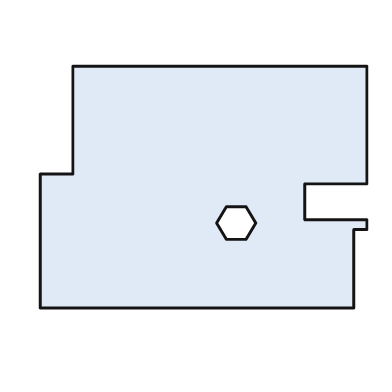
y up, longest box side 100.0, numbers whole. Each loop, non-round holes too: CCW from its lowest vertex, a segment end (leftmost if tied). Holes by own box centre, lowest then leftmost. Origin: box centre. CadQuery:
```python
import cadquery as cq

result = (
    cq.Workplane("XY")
    .moveTo(-50.0, -37.0)
    .lineTo(46.0, -37.0)
    .lineTo(46.0, -13.0)
    .lineTo(50.0, -13.0)
    .lineTo(50.0, -10.0)
    .lineTo(31.0, -10.0)
    .lineTo(31.0, 1.0)
    .lineTo(50.0, 1.0)
    .lineTo(50.0, 37.0)
    .lineTo(-40.0, 37.0)
    .lineTo(-40.0, 4.0)
    .lineTo(-50.0, 4.0)
    .close()
    .moveTo(7.0, -16.0)
    .lineTo(13.0, -16.0)
    .lineTo(16.0, -11.0)
    .lineTo(13.0, -6.0)
    .lineTo(7.0, -6.0)
    .lineTo(4.0, -11.0)
    .close()
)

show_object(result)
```